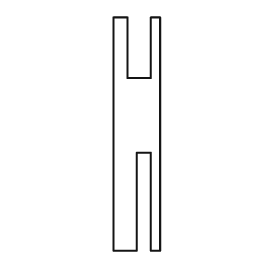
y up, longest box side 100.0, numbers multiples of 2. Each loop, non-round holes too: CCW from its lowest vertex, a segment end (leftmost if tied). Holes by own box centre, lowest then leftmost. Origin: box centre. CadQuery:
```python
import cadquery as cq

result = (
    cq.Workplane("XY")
    .moveTo(-10.0, -50.0)
    .lineTo(0.0, -50.0)
    .lineTo(0.0, -8.0)
    .lineTo(6.0, -8.0)
    .lineTo(6.0, -50.0)
    .lineTo(10.0, -50.0)
    .lineTo(10.0, 50.0)
    .lineTo(6.0, 50.0)
    .lineTo(6.0, 24.0)
    .lineTo(-4.0, 24.0)
    .lineTo(-4.0, 50.0)
    .lineTo(-10.0, 50.0)
    .close()
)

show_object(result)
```